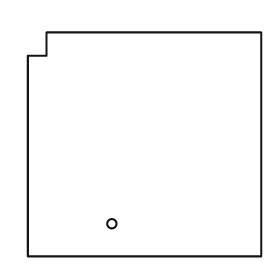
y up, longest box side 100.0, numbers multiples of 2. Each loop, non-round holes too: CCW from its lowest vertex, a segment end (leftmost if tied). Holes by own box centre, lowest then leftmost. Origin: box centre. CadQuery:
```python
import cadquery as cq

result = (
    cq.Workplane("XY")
    .moveTo(-50.0, -48.0)
    .lineTo(50.0, -48.0)
    .lineTo(50.0, 48.0)
    .lineTo(-42.0, 48.0)
    .lineTo(-42.0, 38.0)
    .lineTo(-50.0, 38.0)
    .close()
    .moveTo(-14.0, -34.0)
    .circle(2.0)
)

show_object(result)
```